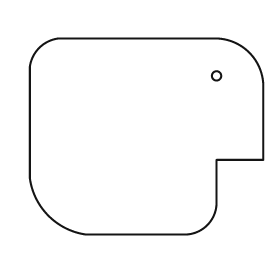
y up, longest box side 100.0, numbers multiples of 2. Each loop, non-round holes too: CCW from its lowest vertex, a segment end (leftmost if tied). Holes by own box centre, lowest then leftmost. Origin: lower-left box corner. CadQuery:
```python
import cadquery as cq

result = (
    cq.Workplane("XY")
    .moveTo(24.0, 0.0)
    .lineTo(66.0, 0.0)
    .threePointArc((76.0, 4.0), (80.0, 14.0))
    .lineTo(80.0, 32.0)
    .lineTo(100.0, 32.0)
    .lineTo(100.0, 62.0)
    .threePointArc((94.0, 78.0), (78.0, 84.0))
    .lineTo(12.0, 84.0)
    .threePointArc((4.0, 80.0), (0.0, 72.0))
    .lineTo(0.0, 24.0)
    .threePointArc((8.0, 8.0), (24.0, 0.0))
    .close()
    .moveTo(80.0, 68.0)
    .circle(2.0)
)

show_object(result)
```